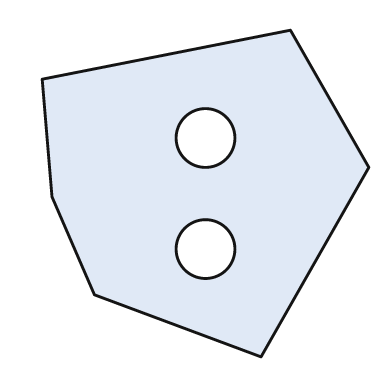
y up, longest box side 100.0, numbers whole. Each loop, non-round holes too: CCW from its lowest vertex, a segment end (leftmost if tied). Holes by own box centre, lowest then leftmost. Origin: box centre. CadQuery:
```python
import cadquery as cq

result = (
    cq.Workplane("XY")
    .moveTo(17.0, -50.0)
    .lineTo(50.0, 8.0)
    .lineTo(26.0, 50.0)
    .lineTo(-50.0, 35.0)
    .lineTo(-47.0, -1.0)
    .lineTo(-34.0, -31.0)
    .close()
    .moveTo(0.0, -17.0)
    .circle(9.0)
    .moveTo(0.0, 17.0)
    .circle(9.0)
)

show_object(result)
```